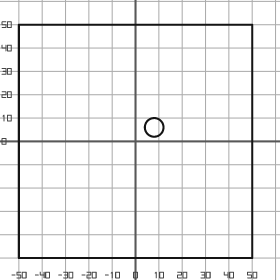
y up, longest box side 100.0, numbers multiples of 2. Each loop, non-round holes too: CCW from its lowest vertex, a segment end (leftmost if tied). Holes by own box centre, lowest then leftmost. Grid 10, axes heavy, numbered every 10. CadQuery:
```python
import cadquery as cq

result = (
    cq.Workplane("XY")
    .moveTo(-50.0, -50.0)
    .lineTo(50.0, -50.0)
    .lineTo(50.0, 50.0)
    .lineTo(-50.0, 50.0)
    .close()
    .moveTo(8.0, 6.0)
    .circle(4.0)
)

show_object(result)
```